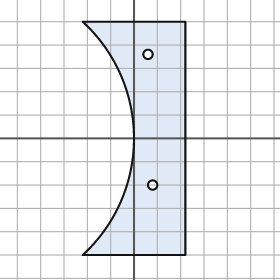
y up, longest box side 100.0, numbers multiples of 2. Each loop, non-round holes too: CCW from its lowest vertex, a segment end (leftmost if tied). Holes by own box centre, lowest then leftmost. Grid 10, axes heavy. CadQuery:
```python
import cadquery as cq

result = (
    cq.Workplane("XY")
    .moveTo(-22.0, -50.0)
    .lineTo(22.0, -50.0)
    .lineTo(22.0, 50.0)
    .lineTo(-22.0, 50.0)
    .threePointArc((0.0, 0.0), (-22.0, -50.0))
    .close()
    .moveTo(8.0, -20.0)
    .circle(2.0)
    .moveTo(6.0, 36.0)
    .circle(2.0)
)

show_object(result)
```